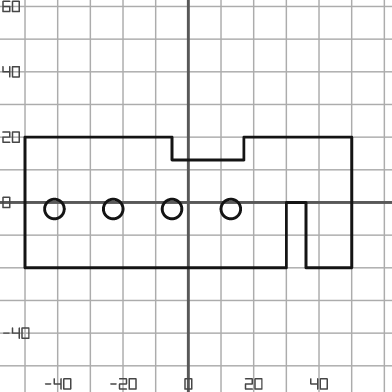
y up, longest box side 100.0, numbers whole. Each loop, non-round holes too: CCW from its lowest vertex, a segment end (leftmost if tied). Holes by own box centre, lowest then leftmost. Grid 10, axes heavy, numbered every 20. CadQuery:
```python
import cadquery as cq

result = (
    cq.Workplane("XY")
    .moveTo(-50.0, -20.0)
    .lineTo(30.0, -20.0)
    .lineTo(30.0, 0.0)
    .lineTo(36.0, 0.0)
    .lineTo(36.0, -20.0)
    .lineTo(50.0, -20.0)
    .lineTo(50.0, 20.0)
    .lineTo(17.0, 20.0)
    .lineTo(17.0, 13.0)
    .lineTo(-5.0, 13.0)
    .lineTo(-5.0, 20.0)
    .lineTo(-50.0, 20.0)
    .close()
    .moveTo(-41.0, -2.0)
    .circle(3.0)
    .moveTo(-23.0, -2.0)
    .circle(3.0)
    .moveTo(-5.0, -2.0)
    .circle(3.0)
    .moveTo(13.0, -2.0)
    .circle(3.0)
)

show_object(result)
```